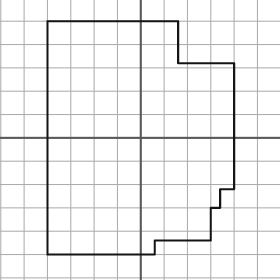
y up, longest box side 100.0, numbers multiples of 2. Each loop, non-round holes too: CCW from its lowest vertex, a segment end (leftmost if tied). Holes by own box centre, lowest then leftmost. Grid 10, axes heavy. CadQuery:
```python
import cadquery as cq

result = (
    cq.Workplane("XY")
    .moveTo(-40.0, -50.0)
    .lineTo(6.0, -50.0)
    .lineTo(6.0, -44.0)
    .lineTo(30.0, -44.0)
    .lineTo(30.0, -30.0)
    .lineTo(34.0, -30.0)
    .lineTo(34.0, -22.0)
    .lineTo(40.0, -22.0)
    .lineTo(40.0, 32.0)
    .lineTo(16.0, 32.0)
    .lineTo(16.0, 50.0)
    .lineTo(-40.0, 50.0)
    .close()
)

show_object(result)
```